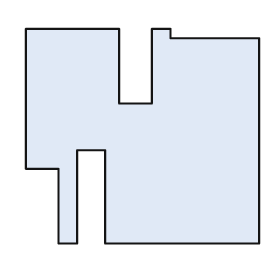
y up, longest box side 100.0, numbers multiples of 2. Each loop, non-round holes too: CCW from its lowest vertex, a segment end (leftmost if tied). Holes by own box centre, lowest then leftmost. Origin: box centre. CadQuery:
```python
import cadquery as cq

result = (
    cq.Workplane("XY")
    .moveTo(-36.0, -46.0)
    .lineTo(-28.0, -46.0)
    .lineTo(-28.0, -6.0)
    .lineTo(-16.0, -6.0)
    .lineTo(-16.0, -46.0)
    .lineTo(50.0, -46.0)
    .lineTo(50.0, 42.0)
    .lineTo(12.0, 42.0)
    .lineTo(12.0, 46.0)
    .lineTo(4.0, 46.0)
    .lineTo(4.0, 14.0)
    .lineTo(-10.0, 14.0)
    .lineTo(-10.0, 46.0)
    .lineTo(-50.0, 46.0)
    .lineTo(-50.0, -14.0)
    .lineTo(-36.0, -14.0)
    .close()
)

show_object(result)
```